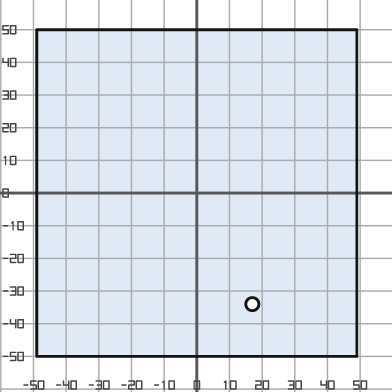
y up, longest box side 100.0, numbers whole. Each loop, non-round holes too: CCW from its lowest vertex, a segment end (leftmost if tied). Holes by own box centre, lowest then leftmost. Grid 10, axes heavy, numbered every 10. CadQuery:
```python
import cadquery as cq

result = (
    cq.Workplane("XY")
    .moveTo(-49.0, -50.0)
    .lineTo(49.0, -50.0)
    .lineTo(49.0, 50.0)
    .lineTo(-49.0, 50.0)
    .close()
    .moveTo(17.0, -34.0)
    .circle(2.0)
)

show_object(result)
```